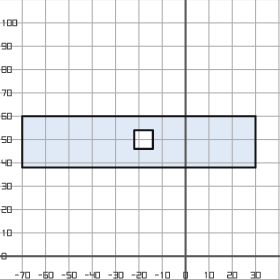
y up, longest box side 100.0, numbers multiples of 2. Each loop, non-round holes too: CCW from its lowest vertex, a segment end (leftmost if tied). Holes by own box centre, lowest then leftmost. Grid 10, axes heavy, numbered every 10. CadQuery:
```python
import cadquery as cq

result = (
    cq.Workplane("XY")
    .moveTo(-70.0, 38.0)
    .lineTo(30.0, 38.0)
    .lineTo(30.0, 60.0)
    .lineTo(-70.0, 60.0)
    .close()
    .moveTo(-22.0, 46.0)
    .lineTo(-14.0, 46.0)
    .lineTo(-14.0, 54.0)
    .lineTo(-22.0, 54.0)
    .close()
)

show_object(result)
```